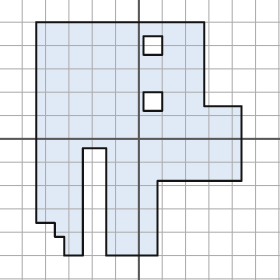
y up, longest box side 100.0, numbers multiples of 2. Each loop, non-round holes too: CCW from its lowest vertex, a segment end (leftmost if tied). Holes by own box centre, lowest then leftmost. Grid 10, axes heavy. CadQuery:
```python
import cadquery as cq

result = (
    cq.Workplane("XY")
    .moveTo(-32.0, -50.0)
    .lineTo(-24.0, -50.0)
    .lineTo(-24.0, -4.0)
    .lineTo(-14.0, -4.0)
    .lineTo(-14.0, -50.0)
    .lineTo(8.0, -50.0)
    .lineTo(8.0, -18.0)
    .lineTo(44.0, -18.0)
    .lineTo(44.0, 14.0)
    .lineTo(28.0, 14.0)
    .lineTo(28.0, 50.0)
    .lineTo(-44.0, 50.0)
    .lineTo(-44.0, -36.0)
    .lineTo(-36.0, -36.0)
    .lineTo(-36.0, -42.0)
    .lineTo(-32.0, -42.0)
    .close()
    .moveTo(2.0, 12.0)
    .lineTo(10.0, 12.0)
    .lineTo(10.0, 20.0)
    .lineTo(2.0, 20.0)
    .close()
    .moveTo(2.0, 36.0)
    .lineTo(10.0, 36.0)
    .lineTo(10.0, 44.0)
    .lineTo(2.0, 44.0)
    .close()
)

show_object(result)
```